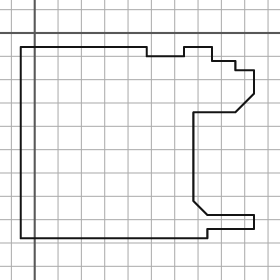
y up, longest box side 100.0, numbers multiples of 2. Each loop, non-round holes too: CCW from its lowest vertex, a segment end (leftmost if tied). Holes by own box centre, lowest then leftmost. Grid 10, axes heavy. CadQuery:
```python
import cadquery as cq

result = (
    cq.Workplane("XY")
    .moveTo(-6.0, -88.0)
    .lineTo(74.0, -88.0)
    .lineTo(74.0, -84.0)
    .lineTo(94.0, -84.0)
    .lineTo(94.0, -78.0)
    .lineTo(74.0, -78.0)
    .lineTo(68.0, -72.0)
    .lineTo(68.0, -34.0)
    .lineTo(86.0, -34.0)
    .lineTo(94.0, -26.0)
    .lineTo(94.0, -16.0)
    .lineTo(86.0, -16.0)
    .lineTo(86.0, -12.0)
    .lineTo(76.0, -12.0)
    .lineTo(76.0, -6.0)
    .lineTo(64.0, -6.0)
    .lineTo(64.0, -10.0)
    .lineTo(48.0, -10.0)
    .lineTo(48.0, -6.0)
    .lineTo(-6.0, -6.0)
    .close()
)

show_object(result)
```